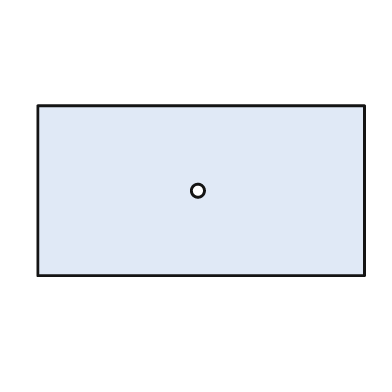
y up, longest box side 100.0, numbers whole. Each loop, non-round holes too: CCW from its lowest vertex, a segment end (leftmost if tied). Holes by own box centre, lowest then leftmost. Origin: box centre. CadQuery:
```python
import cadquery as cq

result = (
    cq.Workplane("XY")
    .moveTo(-50.0, -26.0)
    .lineTo(50.0, -26.0)
    .lineTo(50.0, 26.0)
    .lineTo(-50.0, 26.0)
    .close()
    .moveTo(-1.0, 0.0)
    .circle(2.0)
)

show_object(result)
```